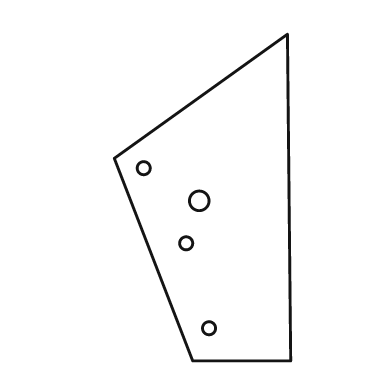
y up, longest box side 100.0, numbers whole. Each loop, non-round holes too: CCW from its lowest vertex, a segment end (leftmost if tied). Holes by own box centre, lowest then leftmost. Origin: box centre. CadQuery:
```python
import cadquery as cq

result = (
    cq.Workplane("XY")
    .moveTo(-3.0, -50.0)
    .lineTo(27.0, -50.0)
    .lineTo(26.0, 50.0)
    .lineTo(-27.0, 12.0)
    .close()
    .moveTo(2.0, -40.0)
    .circle(2.0)
    .moveTo(-5.0, -14.0)
    .circle(2.0)
    .moveTo(-1.0, -1.0)
    .circle(3.0)
    .moveTo(-18.0, 9.0)
    .circle(2.0)
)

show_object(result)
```